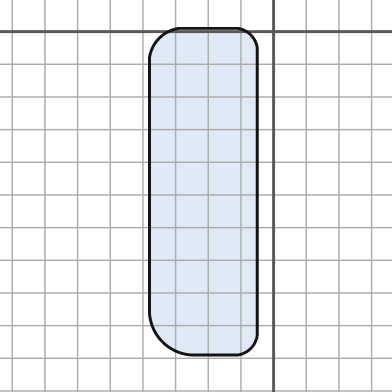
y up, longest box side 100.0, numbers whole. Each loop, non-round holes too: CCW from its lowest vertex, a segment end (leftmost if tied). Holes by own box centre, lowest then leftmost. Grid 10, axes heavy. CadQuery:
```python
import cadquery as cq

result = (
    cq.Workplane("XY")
    .moveTo(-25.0, -99.0)
    .lineTo(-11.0, -99.0)
    .threePointArc((-7.0, -97.0), (-5.0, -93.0))
    .lineTo(-5.0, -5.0)
    .threePointArc((-7.0, -1.0), (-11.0, 1.0))
    .lineTo(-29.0, 1.0)
    .threePointArc((-35.0, -2.0), (-38.0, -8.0))
    .lineTo(-38.0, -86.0)
    .threePointArc((-34.0, -95.0), (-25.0, -99.0))
    .close()
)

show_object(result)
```